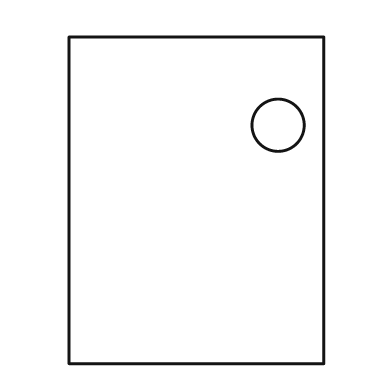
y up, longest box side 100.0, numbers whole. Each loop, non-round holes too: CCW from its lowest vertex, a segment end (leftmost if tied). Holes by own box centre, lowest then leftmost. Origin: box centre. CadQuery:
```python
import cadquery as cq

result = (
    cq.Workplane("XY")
    .moveTo(-39.0, -50.0)
    .lineTo(39.0, -50.0)
    .lineTo(39.0, 50.0)
    .lineTo(-39.0, 50.0)
    .close()
    .moveTo(25.0, 23.0)
    .circle(8.0)
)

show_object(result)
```